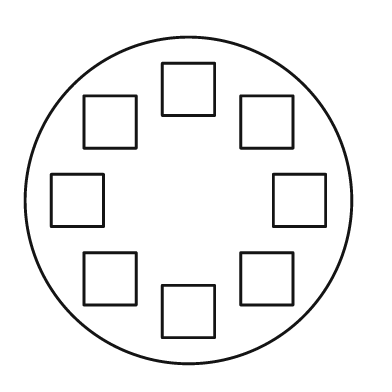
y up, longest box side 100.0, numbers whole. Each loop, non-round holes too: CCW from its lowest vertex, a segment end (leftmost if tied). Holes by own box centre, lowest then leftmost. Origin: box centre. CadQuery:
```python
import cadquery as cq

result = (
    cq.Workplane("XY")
    .moveTo(0.0, 0.0)
    .circle(50.0)
    .moveTo(-8.0, -42.0)
    .lineTo(8.0, -42.0)
    .lineTo(8.0, -26.0)
    .lineTo(-8.0, -26.0)
    .close()
    .moveTo(-32.0, -32.0)
    .lineTo(-16.0, -32.0)
    .lineTo(-16.0, -16.0)
    .lineTo(-32.0, -16.0)
    .close()
    .moveTo(16.0, -32.0)
    .lineTo(32.0, -32.0)
    .lineTo(32.0, -16.0)
    .lineTo(16.0, -16.0)
    .close()
    .moveTo(-42.0, -8.0)
    .lineTo(-26.0, -8.0)
    .lineTo(-26.0, 8.0)
    .lineTo(-42.0, 8.0)
    .close()
    .moveTo(26.0, -8.0)
    .lineTo(42.0, -8.0)
    .lineTo(42.0, 8.0)
    .lineTo(26.0, 8.0)
    .close()
    .moveTo(-32.0, 16.0)
    .lineTo(-16.0, 16.0)
    .lineTo(-16.0, 32.0)
    .lineTo(-32.0, 32.0)
    .close()
    .moveTo(16.0, 16.0)
    .lineTo(32.0, 16.0)
    .lineTo(32.0, 32.0)
    .lineTo(16.0, 32.0)
    .close()
    .moveTo(-8.0, 26.0)
    .lineTo(8.0, 26.0)
    .lineTo(8.0, 42.0)
    .lineTo(-8.0, 42.0)
    .close()
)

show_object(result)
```